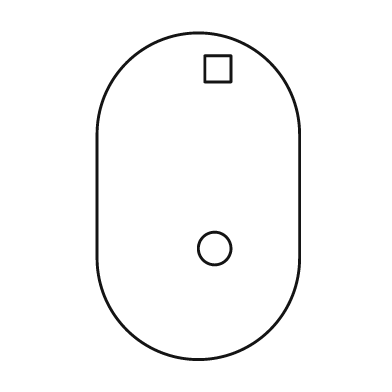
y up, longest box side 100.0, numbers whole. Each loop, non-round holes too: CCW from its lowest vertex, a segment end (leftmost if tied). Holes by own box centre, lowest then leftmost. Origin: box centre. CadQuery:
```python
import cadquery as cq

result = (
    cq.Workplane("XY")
    .moveTo(-31.0, -19.0)
    .threePointArc((0.0, -50.0), (31.0, -19.0))
    .lineTo(31.0, 19.0)
    .threePointArc((0.0, 50.0), (-31.0, 19.0))
    .close()
    .moveTo(5.0, -16.0)
    .circle(5.0)
    .moveTo(2.0, 35.0)
    .lineTo(10.0, 35.0)
    .lineTo(10.0, 43.0)
    .lineTo(2.0, 43.0)
    .close()
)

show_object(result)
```